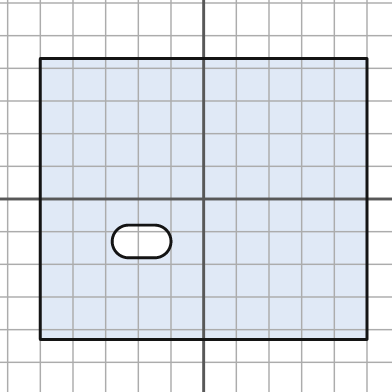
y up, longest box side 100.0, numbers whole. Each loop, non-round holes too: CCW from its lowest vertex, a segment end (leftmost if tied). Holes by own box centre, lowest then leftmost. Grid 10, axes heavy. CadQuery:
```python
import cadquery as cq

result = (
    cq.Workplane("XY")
    .moveTo(-50.0, -43.0)
    .lineTo(50.0, -43.0)
    .lineTo(50.0, 43.0)
    .lineTo(-50.0, 43.0)
    .close()
    .moveTo(-23.0, -18.0)
    .lineTo(-15.0, -18.0)
    .threePointArc((-10.0, -13.0), (-15.0, -8.0))
    .lineTo(-23.0, -8.0)
    .threePointArc((-28.0, -13.0), (-23.0, -18.0))
    .close()
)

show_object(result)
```